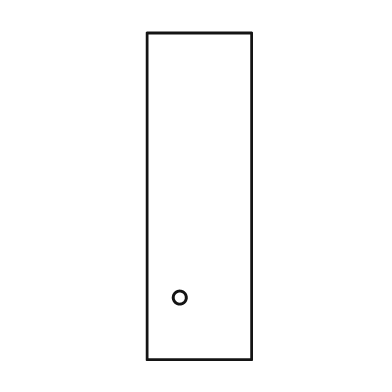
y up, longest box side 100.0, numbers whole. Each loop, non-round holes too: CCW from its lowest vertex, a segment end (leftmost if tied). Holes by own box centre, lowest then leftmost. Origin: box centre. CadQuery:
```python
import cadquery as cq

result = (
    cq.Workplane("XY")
    .moveTo(-16.0, -50.0)
    .lineTo(16.0, -50.0)
    .lineTo(16.0, 50.0)
    .lineTo(-16.0, 50.0)
    .close()
    .moveTo(-6.0, -31.0)
    .circle(2.0)
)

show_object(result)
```